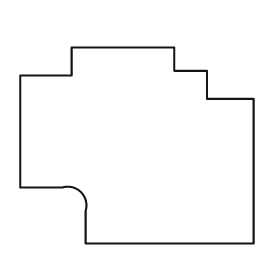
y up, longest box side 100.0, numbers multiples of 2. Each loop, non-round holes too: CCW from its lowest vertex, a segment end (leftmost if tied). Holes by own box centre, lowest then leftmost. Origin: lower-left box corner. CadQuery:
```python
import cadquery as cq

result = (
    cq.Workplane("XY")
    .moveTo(28.0, 0.0)
    .lineTo(100.0, 0.0)
    .lineTo(100.0, 62.0)
    .lineTo(80.0, 62.0)
    .lineTo(80.0, 74.0)
    .lineTo(66.0, 74.0)
    .lineTo(66.0, 84.0)
    .lineTo(22.0, 84.0)
    .lineTo(22.0, 72.0)
    .lineTo(0.0, 72.0)
    .lineTo(0.0, 24.0)
    .lineTo(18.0, 24.0)
    .threePointArc((26.0, 22.0), (28.0, 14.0))
    .close()
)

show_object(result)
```